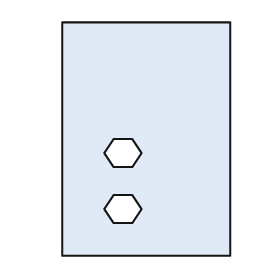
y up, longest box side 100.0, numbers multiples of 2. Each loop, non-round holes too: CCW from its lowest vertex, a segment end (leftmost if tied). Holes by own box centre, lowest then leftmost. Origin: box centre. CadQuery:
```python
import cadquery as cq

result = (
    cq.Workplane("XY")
    .moveTo(-36.0, -50.0)
    .lineTo(36.0, -50.0)
    .lineTo(36.0, 50.0)
    .lineTo(-36.0, 50.0)
    .close()
    .moveTo(-14.0, -36.0)
    .lineTo(-6.0, -36.0)
    .lineTo(-2.0, -30.0)
    .lineTo(-6.0, -24.0)
    .lineTo(-14.0, -24.0)
    .lineTo(-18.0, -30.0)
    .close()
    .moveTo(-14.0, -12.0)
    .lineTo(-6.0, -12.0)
    .lineTo(-2.0, -6.0)
    .lineTo(-6.0, 0.0)
    .lineTo(-14.0, 0.0)
    .lineTo(-18.0, -6.0)
    .close()
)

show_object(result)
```